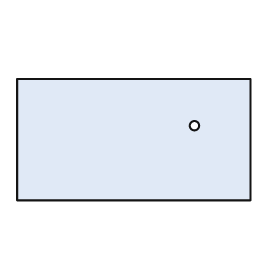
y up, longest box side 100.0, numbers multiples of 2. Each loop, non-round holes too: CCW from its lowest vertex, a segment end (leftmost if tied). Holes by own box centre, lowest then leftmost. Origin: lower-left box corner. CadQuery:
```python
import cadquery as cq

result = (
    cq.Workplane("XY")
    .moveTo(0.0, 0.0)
    .lineTo(100.0, 0.0)
    .lineTo(100.0, 52.0)
    .lineTo(0.0, 52.0)
    .close()
    .moveTo(76.0, 32.0)
    .circle(2.0)
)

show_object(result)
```